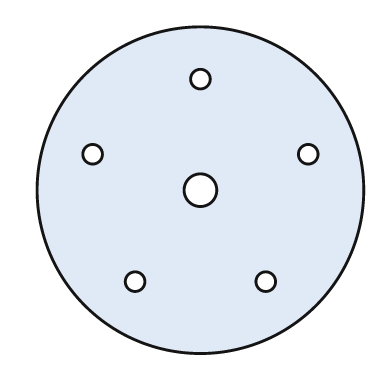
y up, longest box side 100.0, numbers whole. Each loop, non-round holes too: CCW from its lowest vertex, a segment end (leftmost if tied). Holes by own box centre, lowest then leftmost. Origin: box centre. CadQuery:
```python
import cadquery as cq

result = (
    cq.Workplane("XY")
    .moveTo(0.0, 0.0)
    .circle(50.0)
    .moveTo(-20.0, -28.0)
    .circle(3.0)
    .moveTo(20.0, -28.0)
    .circle(3.0)
    .moveTo(0.0, 0.0)
    .circle(5.0)
    .moveTo(-33.0, 11.0)
    .circle(3.0)
    .moveTo(33.0, 11.0)
    .circle(3.0)
    .moveTo(0.0, 34.0)
    .circle(3.0)
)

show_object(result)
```